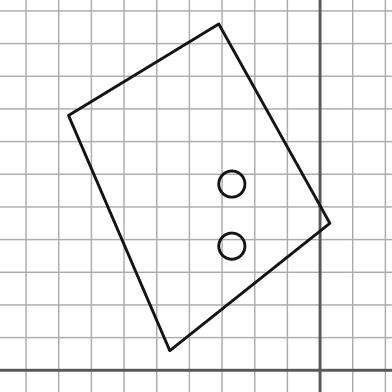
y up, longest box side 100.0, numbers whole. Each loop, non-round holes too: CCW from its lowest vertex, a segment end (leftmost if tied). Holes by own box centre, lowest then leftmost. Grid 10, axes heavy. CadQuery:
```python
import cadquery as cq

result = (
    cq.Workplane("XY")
    .moveTo(-46.0, 6.0)
    .lineTo(3.0, 45.0)
    .lineTo(-31.0, 106.0)
    .lineTo(-77.0, 78.0)
    .close()
    .moveTo(-27.0, 38.0)
    .circle(4.0)
    .moveTo(-27.0, 57.0)
    .circle(4.0)
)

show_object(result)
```